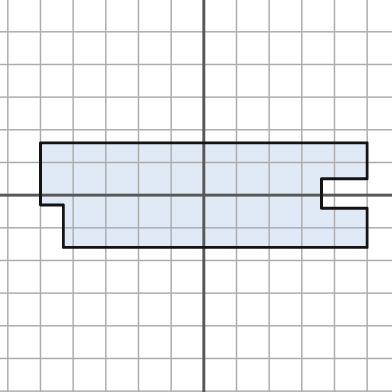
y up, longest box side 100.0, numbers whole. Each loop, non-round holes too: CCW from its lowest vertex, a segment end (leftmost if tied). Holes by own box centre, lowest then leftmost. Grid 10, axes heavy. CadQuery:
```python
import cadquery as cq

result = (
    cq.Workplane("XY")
    .moveTo(-43.0, -16.0)
    .lineTo(50.0, -16.0)
    .lineTo(50.0, -4.0)
    .lineTo(36.0, -4.0)
    .lineTo(36.0, 5.0)
    .lineTo(50.0, 5.0)
    .lineTo(50.0, 16.0)
    .lineTo(-50.0, 16.0)
    .lineTo(-50.0, -3.0)
    .lineTo(-43.0, -3.0)
    .close()
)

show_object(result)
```